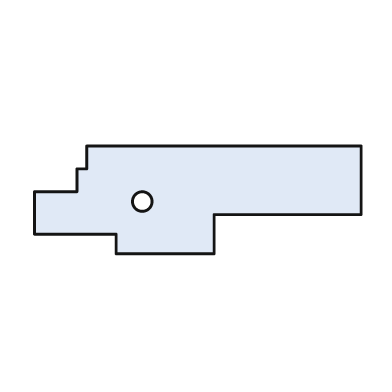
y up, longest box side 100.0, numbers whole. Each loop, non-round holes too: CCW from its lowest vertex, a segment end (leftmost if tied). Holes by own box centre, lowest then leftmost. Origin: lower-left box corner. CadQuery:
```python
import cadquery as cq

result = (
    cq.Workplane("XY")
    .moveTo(25.0, 0.0)
    .lineTo(55.0, 0.0)
    .lineTo(55.0, 12.0)
    .lineTo(100.0, 12.0)
    .lineTo(100.0, 33.0)
    .lineTo(16.0, 33.0)
    .lineTo(16.0, 26.0)
    .lineTo(13.0, 26.0)
    .lineTo(13.0, 19.0)
    .lineTo(0.0, 19.0)
    .lineTo(0.0, 6.0)
    .lineTo(25.0, 6.0)
    .close()
    .moveTo(33.0, 16.0)
    .circle(3.0)
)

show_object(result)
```